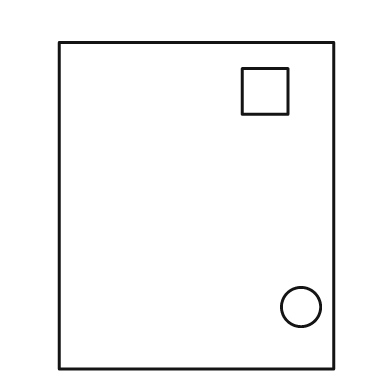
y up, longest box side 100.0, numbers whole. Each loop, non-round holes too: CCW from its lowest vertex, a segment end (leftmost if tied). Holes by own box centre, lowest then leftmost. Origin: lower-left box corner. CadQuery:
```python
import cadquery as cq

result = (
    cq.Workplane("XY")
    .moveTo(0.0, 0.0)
    .lineTo(84.0, 0.0)
    .lineTo(84.0, 100.0)
    .lineTo(0.0, 100.0)
    .close()
    .moveTo(74.0, 19.0)
    .circle(6.0)
    .moveTo(56.0, 78.0)
    .lineTo(70.0, 78.0)
    .lineTo(70.0, 92.0)
    .lineTo(56.0, 92.0)
    .close()
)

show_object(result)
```